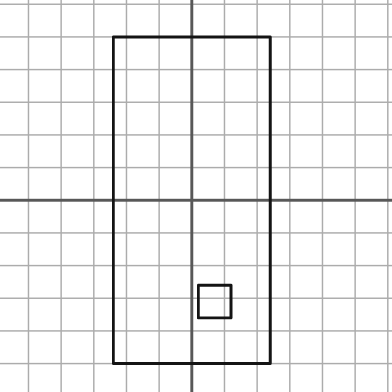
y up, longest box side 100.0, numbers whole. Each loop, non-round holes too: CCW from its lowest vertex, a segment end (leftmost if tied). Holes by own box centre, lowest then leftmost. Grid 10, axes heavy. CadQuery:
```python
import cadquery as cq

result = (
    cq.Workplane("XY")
    .moveTo(-24.0, -50.0)
    .lineTo(24.0, -50.0)
    .lineTo(24.0, 50.0)
    .lineTo(-24.0, 50.0)
    .close()
    .moveTo(2.0, -36.0)
    .lineTo(12.0, -36.0)
    .lineTo(12.0, -26.0)
    .lineTo(2.0, -26.0)
    .close()
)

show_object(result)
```